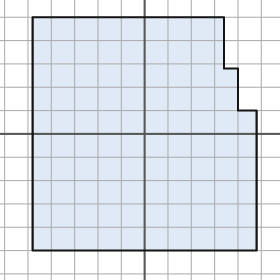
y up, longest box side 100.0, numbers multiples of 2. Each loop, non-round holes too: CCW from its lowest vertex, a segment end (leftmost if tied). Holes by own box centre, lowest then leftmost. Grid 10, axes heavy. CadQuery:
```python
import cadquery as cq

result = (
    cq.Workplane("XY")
    .moveTo(-48.0, -50.0)
    .lineTo(48.0, -50.0)
    .lineTo(48.0, 10.0)
    .lineTo(40.0, 10.0)
    .lineTo(40.0, 28.0)
    .lineTo(34.0, 28.0)
    .lineTo(34.0, 50.0)
    .lineTo(-48.0, 50.0)
    .close()
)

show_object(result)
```